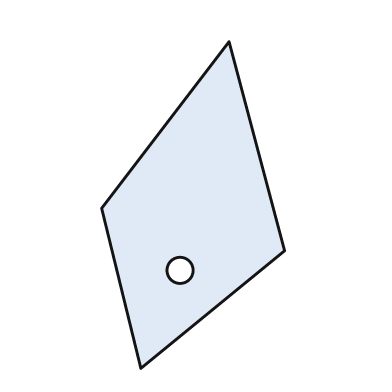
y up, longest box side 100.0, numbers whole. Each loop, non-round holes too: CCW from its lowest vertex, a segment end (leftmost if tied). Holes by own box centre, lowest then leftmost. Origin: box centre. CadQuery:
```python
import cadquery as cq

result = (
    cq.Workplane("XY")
    .moveTo(-16.0, -50.0)
    .lineTo(28.0, -14.0)
    .lineTo(11.0, 50.0)
    .lineTo(-28.0, -1.0)
    .close()
    .moveTo(-4.0, -20.0)
    .circle(4.0)
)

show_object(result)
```